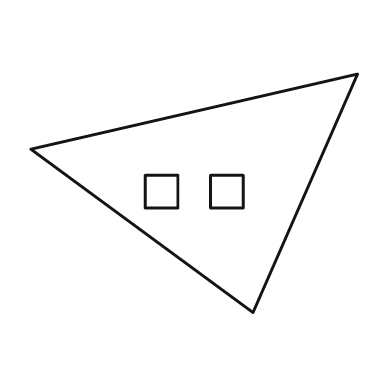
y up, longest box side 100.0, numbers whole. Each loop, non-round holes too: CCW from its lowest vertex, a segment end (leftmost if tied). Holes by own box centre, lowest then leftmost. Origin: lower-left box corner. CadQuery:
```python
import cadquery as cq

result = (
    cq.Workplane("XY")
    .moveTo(68.0, 0.0)
    .lineTo(100.0, 73.0)
    .lineTo(0.0, 50.0)
    .close()
    .moveTo(35.0, 32.0)
    .lineTo(45.0, 32.0)
    .lineTo(45.0, 42.0)
    .lineTo(35.0, 42.0)
    .close()
    .moveTo(55.0, 32.0)
    .lineTo(65.0, 32.0)
    .lineTo(65.0, 42.0)
    .lineTo(55.0, 42.0)
    .close()
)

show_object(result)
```